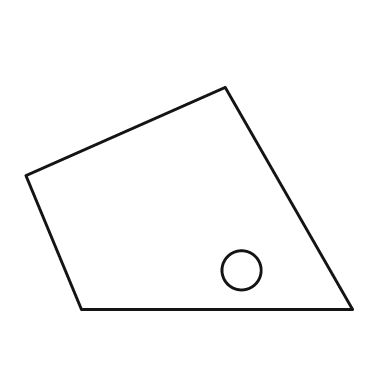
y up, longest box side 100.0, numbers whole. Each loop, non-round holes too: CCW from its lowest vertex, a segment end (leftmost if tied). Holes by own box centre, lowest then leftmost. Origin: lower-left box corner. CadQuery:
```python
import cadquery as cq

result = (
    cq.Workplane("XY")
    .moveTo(17.0, 0.0)
    .lineTo(100.0, 0.0)
    .lineTo(61.0, 68.0)
    .lineTo(0.0, 41.0)
    .close()
    .moveTo(66.0, 12.0)
    .circle(6.0)
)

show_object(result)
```